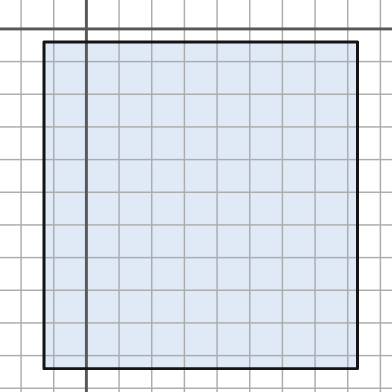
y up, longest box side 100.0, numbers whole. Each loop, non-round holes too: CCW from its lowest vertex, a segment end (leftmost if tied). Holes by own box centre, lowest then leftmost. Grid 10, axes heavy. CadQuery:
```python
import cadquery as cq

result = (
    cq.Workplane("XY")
    .moveTo(-13.0, -104.0)
    .lineTo(83.0, -104.0)
    .lineTo(83.0, -4.0)
    .lineTo(-13.0, -4.0)
    .close()
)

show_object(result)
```